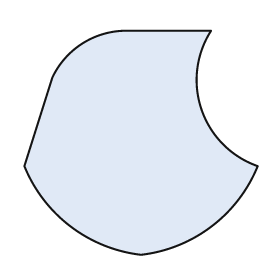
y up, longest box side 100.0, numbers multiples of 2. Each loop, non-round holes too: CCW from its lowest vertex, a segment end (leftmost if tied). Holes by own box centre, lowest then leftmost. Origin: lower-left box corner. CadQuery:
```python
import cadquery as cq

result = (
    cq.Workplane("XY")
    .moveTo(50.0, 0.0)
    .threePointArc((80.0, 12.0), (100.0, 38.0))
    .threePointArc((76.0, 62.0), (80.0, 96.0))
    .lineTo(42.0, 96.0)
    .threePointArc((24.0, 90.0), (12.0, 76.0))
    .lineTo(0.0, 38.0)
    .threePointArc((20.0, 12.0), (50.0, 0.0))
    .close()
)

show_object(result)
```